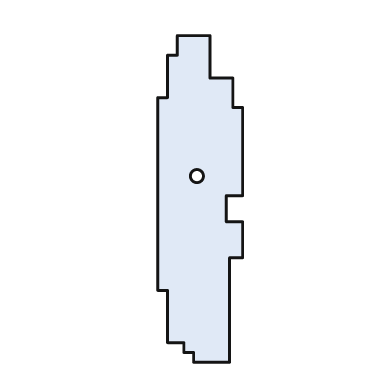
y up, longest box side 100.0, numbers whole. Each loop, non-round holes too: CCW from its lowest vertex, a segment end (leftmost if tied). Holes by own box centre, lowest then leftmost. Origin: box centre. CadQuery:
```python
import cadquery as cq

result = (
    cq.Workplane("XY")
    .moveTo(-2.0, -50.0)
    .lineTo(9.0, -50.0)
    .lineTo(9.0, -18.0)
    .lineTo(13.0, -18.0)
    .lineTo(13.0, -7.0)
    .lineTo(8.0, -7.0)
    .lineTo(8.0, 1.0)
    .lineTo(13.0, 1.0)
    .lineTo(13.0, 28.0)
    .lineTo(10.0, 28.0)
    .lineTo(10.0, 37.0)
    .lineTo(3.0, 37.0)
    .lineTo(3.0, 50.0)
    .lineTo(-7.0, 50.0)
    .lineTo(-7.0, 44.0)
    .lineTo(-10.0, 44.0)
    .lineTo(-10.0, 31.0)
    .lineTo(-13.0, 31.0)
    .lineTo(-13.0, -28.0)
    .lineTo(-10.0, -28.0)
    .lineTo(-10.0, -44.0)
    .lineTo(-5.0, -44.0)
    .lineTo(-5.0, -47.0)
    .lineTo(-2.0, -47.0)
    .close()
    .moveTo(-1.0, 7.0)
    .circle(2.0)
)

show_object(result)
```